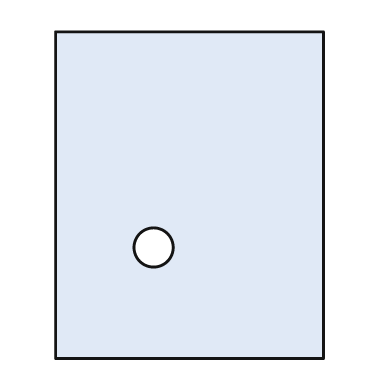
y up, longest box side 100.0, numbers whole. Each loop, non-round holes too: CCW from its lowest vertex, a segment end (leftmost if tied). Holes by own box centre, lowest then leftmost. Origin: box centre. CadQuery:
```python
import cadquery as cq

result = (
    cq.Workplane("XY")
    .moveTo(-41.0, -50.0)
    .lineTo(41.0, -50.0)
    .lineTo(41.0, 50.0)
    .lineTo(-41.0, 50.0)
    .close()
    .moveTo(-11.0, -16.0)
    .circle(6.0)
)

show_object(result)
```